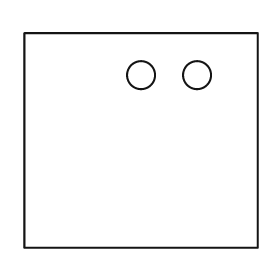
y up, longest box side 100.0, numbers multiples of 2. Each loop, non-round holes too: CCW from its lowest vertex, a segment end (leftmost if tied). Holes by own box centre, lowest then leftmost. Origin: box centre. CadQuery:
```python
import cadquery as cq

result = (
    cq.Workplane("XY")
    .moveTo(-50.0, -46.0)
    .lineTo(50.0, -46.0)
    .lineTo(50.0, 46.0)
    .lineTo(-50.0, 46.0)
    .close()
    .moveTo(0.0, 28.0)
    .circle(6.0)
    .moveTo(24.0, 28.0)
    .circle(6.0)
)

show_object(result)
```